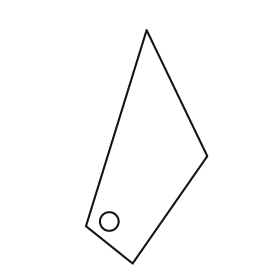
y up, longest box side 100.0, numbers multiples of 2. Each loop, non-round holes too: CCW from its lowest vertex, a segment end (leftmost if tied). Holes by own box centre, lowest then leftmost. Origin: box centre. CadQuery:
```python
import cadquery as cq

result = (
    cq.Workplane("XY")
    .moveTo(-6.0, -50.0)
    .lineTo(26.0, -4.0)
    .lineTo(0.0, 50.0)
    .lineTo(-26.0, -34.0)
    .close()
    .moveTo(-16.0, -32.0)
    .circle(4.0)
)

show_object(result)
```